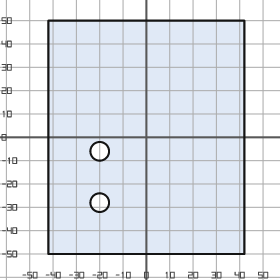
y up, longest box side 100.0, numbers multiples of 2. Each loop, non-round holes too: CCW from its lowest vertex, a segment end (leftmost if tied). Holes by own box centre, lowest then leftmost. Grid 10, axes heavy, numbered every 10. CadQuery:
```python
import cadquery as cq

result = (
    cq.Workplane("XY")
    .moveTo(-42.0, -50.0)
    .lineTo(42.0, -50.0)
    .lineTo(42.0, 50.0)
    .lineTo(-42.0, 50.0)
    .close()
    .moveTo(-20.0, -28.0)
    .circle(4.0)
    .moveTo(-20.0, -6.0)
    .circle(4.0)
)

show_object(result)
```